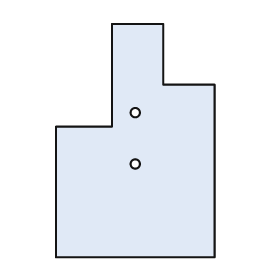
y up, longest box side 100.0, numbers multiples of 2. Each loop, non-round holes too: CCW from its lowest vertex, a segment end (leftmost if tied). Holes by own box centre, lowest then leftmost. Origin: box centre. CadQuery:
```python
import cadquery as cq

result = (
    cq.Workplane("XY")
    .moveTo(-34.0, -50.0)
    .lineTo(34.0, -50.0)
    .lineTo(34.0, 24.0)
    .lineTo(12.0, 24.0)
    .lineTo(12.0, 50.0)
    .lineTo(-10.0, 50.0)
    .lineTo(-10.0, 6.0)
    .lineTo(-34.0, 6.0)
    .close()
    .moveTo(0.0, -10.0)
    .circle(2.0)
    .moveTo(0.0, 12.0)
    .circle(2.0)
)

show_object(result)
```